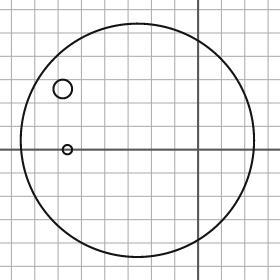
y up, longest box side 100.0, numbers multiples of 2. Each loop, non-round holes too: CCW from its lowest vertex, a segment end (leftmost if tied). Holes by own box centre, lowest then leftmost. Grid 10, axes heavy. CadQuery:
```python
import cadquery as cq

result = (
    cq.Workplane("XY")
    .moveTo(-26.0, 4.0)
    .circle(50.0)
    .moveTo(-56.0, 0.0)
    .circle(2.0)
    .moveTo(-58.0, 26.0)
    .circle(4.0)
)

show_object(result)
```